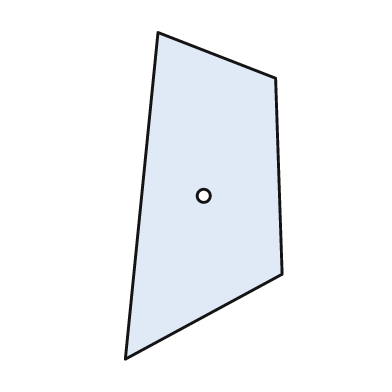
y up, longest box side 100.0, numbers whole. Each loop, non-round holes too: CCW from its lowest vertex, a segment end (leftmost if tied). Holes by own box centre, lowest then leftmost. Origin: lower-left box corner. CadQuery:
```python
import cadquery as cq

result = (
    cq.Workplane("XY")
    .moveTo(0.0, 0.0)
    .lineTo(48.0, 26.0)
    .lineTo(46.0, 86.0)
    .lineTo(10.0, 100.0)
    .close()
    .moveTo(24.0, 50.0)
    .circle(2.0)
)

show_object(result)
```